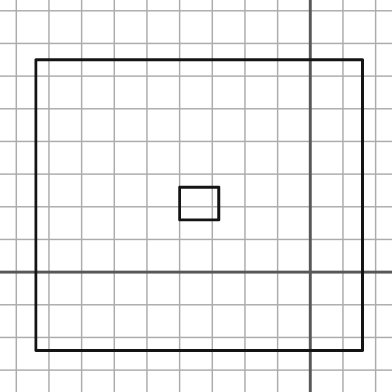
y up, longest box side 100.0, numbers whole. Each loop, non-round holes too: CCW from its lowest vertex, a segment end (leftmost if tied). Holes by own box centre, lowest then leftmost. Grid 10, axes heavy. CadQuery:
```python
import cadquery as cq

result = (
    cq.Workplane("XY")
    .moveTo(-84.0, -24.0)
    .lineTo(16.0, -24.0)
    .lineTo(16.0, 65.0)
    .lineTo(-84.0, 65.0)
    .close()
    .moveTo(-40.0, 16.0)
    .lineTo(-28.0, 16.0)
    .lineTo(-28.0, 26.0)
    .lineTo(-40.0, 26.0)
    .close()
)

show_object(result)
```